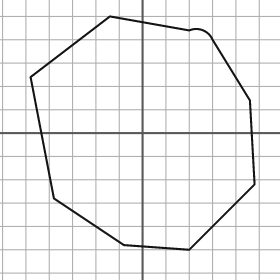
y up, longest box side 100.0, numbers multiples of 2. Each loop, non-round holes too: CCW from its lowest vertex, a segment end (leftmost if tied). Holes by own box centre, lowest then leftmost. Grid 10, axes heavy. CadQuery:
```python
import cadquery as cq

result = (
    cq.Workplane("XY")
    .moveTo(20.0, -50.0)
    .lineTo(48.0, -22.0)
    .lineTo(46.0, 14.0)
    .lineTo(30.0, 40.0)
    .threePointArc((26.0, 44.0), (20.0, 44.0))
    .lineTo(-14.0, 50.0)
    .lineTo(-48.0, 24.0)
    .lineTo(-38.0, -28.0)
    .lineTo(-8.0, -48.0)
    .close()
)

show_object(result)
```